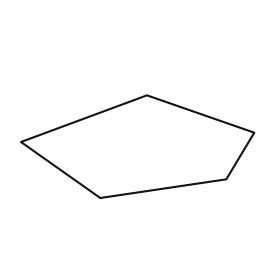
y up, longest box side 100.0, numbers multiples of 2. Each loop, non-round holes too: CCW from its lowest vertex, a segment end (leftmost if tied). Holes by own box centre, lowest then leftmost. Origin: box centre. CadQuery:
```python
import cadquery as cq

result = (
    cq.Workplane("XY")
    .moveTo(-16.0, -22.0)
    .lineTo(38.0, -14.0)
    .lineTo(50.0, 6.0)
    .lineTo(4.0, 22.0)
    .lineTo(-50.0, 2.0)
    .close()
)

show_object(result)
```